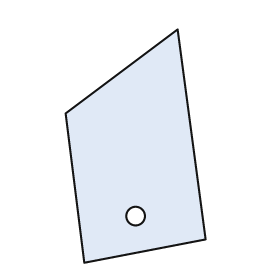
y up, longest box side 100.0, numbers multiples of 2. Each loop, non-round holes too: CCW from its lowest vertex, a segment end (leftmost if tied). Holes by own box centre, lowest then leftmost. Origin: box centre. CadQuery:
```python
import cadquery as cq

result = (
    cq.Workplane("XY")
    .moveTo(-22.0, -50.0)
    .lineTo(30.0, -40.0)
    .lineTo(18.0, 50.0)
    .lineTo(-30.0, 14.0)
    .close()
    .moveTo(0.0, -30.0)
    .circle(4.0)
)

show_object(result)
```